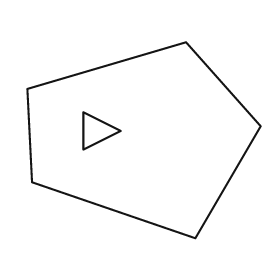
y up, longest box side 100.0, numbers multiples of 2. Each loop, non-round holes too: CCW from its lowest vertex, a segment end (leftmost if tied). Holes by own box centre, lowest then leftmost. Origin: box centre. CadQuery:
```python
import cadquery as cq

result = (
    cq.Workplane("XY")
    .moveTo(22.0, -42.0)
    .lineTo(50.0, 6.0)
    .lineTo(18.0, 42.0)
    .lineTo(-50.0, 22.0)
    .lineTo(-48.0, -18.0)
    .close()
    .moveTo(-26.0, -4.0)
    .lineTo(-10.0, 4.0)
    .lineTo(-26.0, 12.0)
    .close()
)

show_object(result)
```